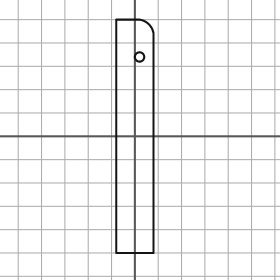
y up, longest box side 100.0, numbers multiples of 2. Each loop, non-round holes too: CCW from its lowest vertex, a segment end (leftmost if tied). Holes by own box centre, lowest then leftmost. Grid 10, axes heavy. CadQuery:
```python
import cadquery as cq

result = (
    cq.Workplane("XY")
    .moveTo(-8.0, -50.0)
    .lineTo(8.0, -50.0)
    .lineTo(8.0, 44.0)
    .threePointArc((6.0, 48.0), (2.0, 50.0))
    .lineTo(-8.0, 50.0)
    .close()
    .moveTo(2.0, 34.0)
    .circle(2.0)
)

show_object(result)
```